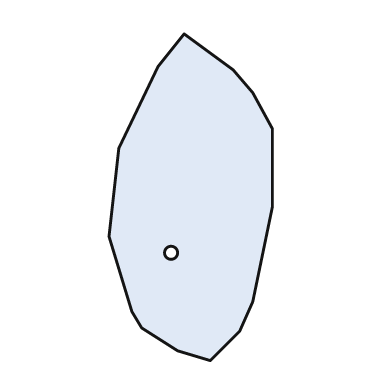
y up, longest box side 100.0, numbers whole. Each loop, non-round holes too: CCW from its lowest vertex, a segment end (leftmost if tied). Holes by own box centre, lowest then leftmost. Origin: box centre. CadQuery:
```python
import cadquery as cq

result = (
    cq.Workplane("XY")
    .moveTo(6.0, -50.0)
    .lineTo(15.0, -41.0)
    .lineTo(19.0, -32.0)
    .lineTo(25.0, -3.0)
    .lineTo(25.0, 21.0)
    .lineTo(19.0, 32.0)
    .lineTo(13.0, 39.0)
    .lineTo(-2.0, 50.0)
    .lineTo(-10.0, 40.0)
    .lineTo(-22.0, 15.0)
    .lineTo(-25.0, -12.0)
    .lineTo(-18.0, -35.0)
    .lineTo(-15.0, -40.0)
    .lineTo(-4.0, -47.0)
    .close()
    .moveTo(-6.0, -17.0)
    .circle(2.0)
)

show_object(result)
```